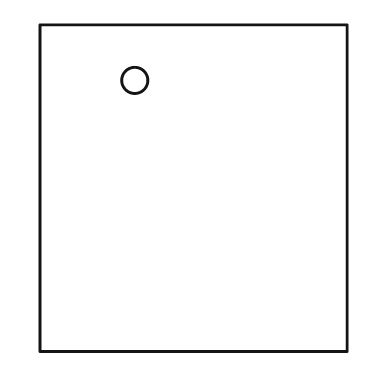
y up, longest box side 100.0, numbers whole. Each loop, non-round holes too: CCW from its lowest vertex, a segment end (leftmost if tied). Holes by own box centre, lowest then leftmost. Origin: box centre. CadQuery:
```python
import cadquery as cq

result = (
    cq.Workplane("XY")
    .moveTo(-47.0, -50.0)
    .lineTo(47.0, -50.0)
    .lineTo(47.0, 50.0)
    .lineTo(-47.0, 50.0)
    .close()
    .moveTo(-18.0, 33.0)
    .circle(4.0)
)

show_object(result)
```